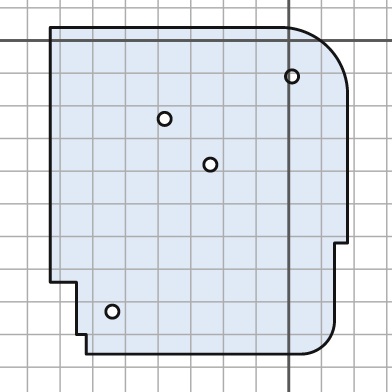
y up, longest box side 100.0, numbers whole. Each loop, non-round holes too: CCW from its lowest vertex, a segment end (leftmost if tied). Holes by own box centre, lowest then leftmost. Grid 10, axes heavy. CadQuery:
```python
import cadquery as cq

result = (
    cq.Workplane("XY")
    .moveTo(-62.0, -96.0)
    .lineTo(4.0, -96.0)
    .threePointArc((11.0, -93.0), (14.0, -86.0))
    .lineTo(14.0, -62.0)
    .lineTo(18.0, -62.0)
    .lineTo(18.0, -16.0)
    .threePointArc((12.0, -2.0), (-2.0, 4.0))
    .lineTo(-73.0, 4.0)
    .lineTo(-73.0, -74.0)
    .lineTo(-65.0, -74.0)
    .lineTo(-65.0, -90.0)
    .lineTo(-62.0, -90.0)
    .close()
    .moveTo(-54.0, -83.0)
    .circle(2.0)
    .moveTo(-24.0, -38.0)
    .circle(2.0)
    .moveTo(-38.0, -24.0)
    .circle(2.0)
    .moveTo(1.0, -11.0)
    .circle(2.0)
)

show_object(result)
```